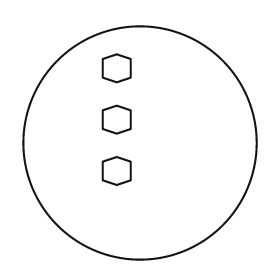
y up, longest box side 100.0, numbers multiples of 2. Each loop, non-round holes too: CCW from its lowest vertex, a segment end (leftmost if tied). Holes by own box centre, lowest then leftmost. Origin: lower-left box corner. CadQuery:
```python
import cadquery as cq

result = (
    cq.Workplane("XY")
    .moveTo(50.0, 50.0)
    .circle(50.0)
    .moveTo(40.0, 32.0)
    .lineTo(46.0, 34.0)
    .lineTo(46.0, 42.0)
    .lineTo(40.0, 44.0)
    .lineTo(34.0, 42.0)
    .lineTo(34.0, 34.0)
    .close()
    .moveTo(40.0, 54.0)
    .lineTo(46.0, 56.0)
    .lineTo(46.0, 64.0)
    .lineTo(40.0, 66.0)
    .lineTo(34.0, 64.0)
    .lineTo(34.0, 56.0)
    .close()
    .moveTo(40.0, 76.0)
    .lineTo(46.0, 78.0)
    .lineTo(46.0, 86.0)
    .lineTo(40.0, 88.0)
    .lineTo(34.0, 86.0)
    .lineTo(34.0, 78.0)
    .close()
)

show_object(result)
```